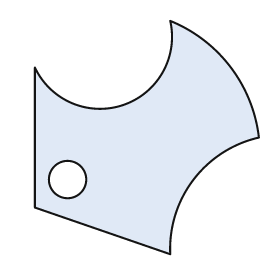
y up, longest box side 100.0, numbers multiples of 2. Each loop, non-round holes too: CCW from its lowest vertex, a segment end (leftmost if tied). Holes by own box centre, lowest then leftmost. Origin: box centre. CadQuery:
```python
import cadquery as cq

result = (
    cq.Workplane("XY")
    .moveTo(10.0, -50.0)
    .threePointArc((20.0, -18.0), (48.0, 0.0))
    .threePointArc((36.0, 30.0), (10.0, 50.0))
    .threePointArc((-10.0, 14.0), (-48.0, 30.0))
    .lineTo(-48.0, -30.0)
    .close()
    .moveTo(-34.0, -18.0)
    .circle(8.0)
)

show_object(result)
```